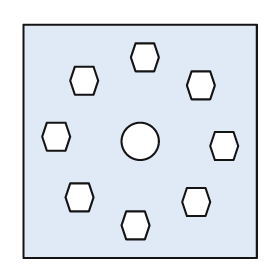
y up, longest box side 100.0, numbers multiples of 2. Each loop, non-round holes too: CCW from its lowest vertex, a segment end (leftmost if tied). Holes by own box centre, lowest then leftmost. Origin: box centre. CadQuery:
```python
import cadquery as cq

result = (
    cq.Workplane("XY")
    .moveTo(-50.0, -50.0)
    .lineTo(50.0, -50.0)
    .lineTo(50.0, 50.0)
    .lineTo(-50.0, 50.0)
    .close()
    .moveTo(-6.0, -42.0)
    .lineTo(2.0, -42.0)
    .lineTo(4.0, -36.0)
    .lineTo(2.0, -30.0)
    .lineTo(-6.0, -30.0)
    .lineTo(-8.0, -36.0)
    .close()
    .moveTo(20.0, -32.0)
    .lineTo(28.0, -32.0)
    .lineTo(30.0, -26.0)
    .lineTo(28.0, -20.0)
    .lineTo(20.0, -20.0)
    .lineTo(18.0, -26.0)
    .close()
    .moveTo(-30.0, -30.0)
    .lineTo(-22.0, -30.0)
    .lineTo(-20.0, -24.0)
    .lineTo(-22.0, -18.0)
    .lineTo(-30.0, -18.0)
    .lineTo(-32.0, -24.0)
    .close()
    .moveTo(32.0, -8.0)
    .lineTo(40.0, -8.0)
    .lineTo(42.0, -2.0)
    .lineTo(40.0, 4.0)
    .lineTo(32.0, 4.0)
    .lineTo(30.0, -2.0)
    .close()
    .moveTo(0.0, 0.0)
    .circle(8.0)
    .moveTo(-40.0, -4.0)
    .lineTo(-32.0, -4.0)
    .lineTo(-30.0, 2.0)
    .lineTo(-32.0, 8.0)
    .lineTo(-40.0, 8.0)
    .lineTo(-42.0, 2.0)
    .close()
    .moveTo(22.0, 18.0)
    .lineTo(30.0, 18.0)
    .lineTo(32.0, 24.0)
    .lineTo(30.0, 30.0)
    .lineTo(22.0, 30.0)
    .lineTo(20.0, 24.0)
    .close()
    .moveTo(-28.0, 20.0)
    .lineTo(-20.0, 20.0)
    .lineTo(-18.0, 26.0)
    .lineTo(-20.0, 32.0)
    .lineTo(-28.0, 32.0)
    .lineTo(-30.0, 26.0)
    .close()
    .moveTo(-2.0, 30.0)
    .lineTo(6.0, 30.0)
    .lineTo(8.0, 36.0)
    .lineTo(6.0, 42.0)
    .lineTo(-2.0, 42.0)
    .lineTo(-4.0, 36.0)
    .close()
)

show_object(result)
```